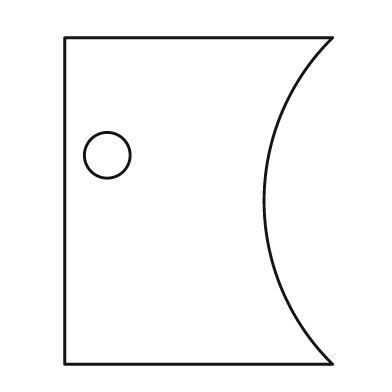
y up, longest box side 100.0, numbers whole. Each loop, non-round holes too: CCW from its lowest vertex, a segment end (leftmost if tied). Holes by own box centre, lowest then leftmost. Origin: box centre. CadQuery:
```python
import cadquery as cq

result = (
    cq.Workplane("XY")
    .moveTo(-41.0, -50.0)
    .lineTo(41.0, -50.0)
    .threePointArc((20.0, 0.0), (41.0, 50.0))
    .lineTo(-41.0, 50.0)
    .close()
    .moveTo(-28.0, 14.0)
    .circle(7.0)
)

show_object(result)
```